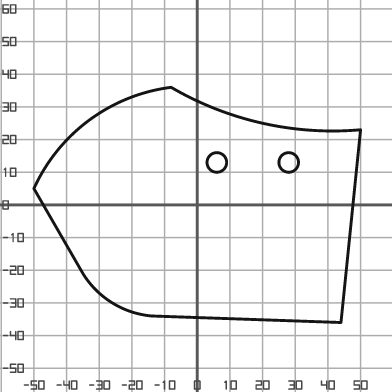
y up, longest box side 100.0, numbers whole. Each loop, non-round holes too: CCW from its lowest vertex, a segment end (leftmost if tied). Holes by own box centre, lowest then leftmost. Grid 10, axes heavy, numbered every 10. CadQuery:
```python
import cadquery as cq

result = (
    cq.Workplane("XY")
    .moveTo(44.0, -36.0)
    .lineTo(50.0, 23.0)
    .threePointArc((20.0, 25.0), (-8.0, 36.0))
    .threePointArc((-33.0, 26.0), (-50.0, 5.0))
    .lineTo(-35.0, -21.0)
    .threePointArc((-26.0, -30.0), (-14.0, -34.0))
    .close()
    .moveTo(6.0, 13.0)
    .circle(3.0)
    .moveTo(28.0, 13.0)
    .circle(3.0)
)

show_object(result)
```